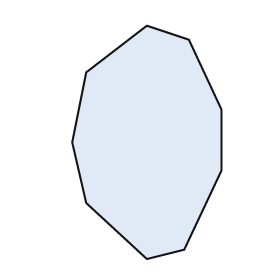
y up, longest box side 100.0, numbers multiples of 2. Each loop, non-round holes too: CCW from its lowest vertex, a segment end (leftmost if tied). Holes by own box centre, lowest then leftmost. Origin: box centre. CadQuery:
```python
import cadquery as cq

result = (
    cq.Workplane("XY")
    .moveTo(0.0, -50.0)
    .lineTo(16.0, -46.0)
    .lineTo(32.0, -12.0)
    .lineTo(32.0, 14.0)
    .lineTo(18.0, 44.0)
    .lineTo(0.0, 50.0)
    .lineTo(-26.0, 30.0)
    .lineTo(-32.0, 0.0)
    .lineTo(-26.0, -26.0)
    .close()
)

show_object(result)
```